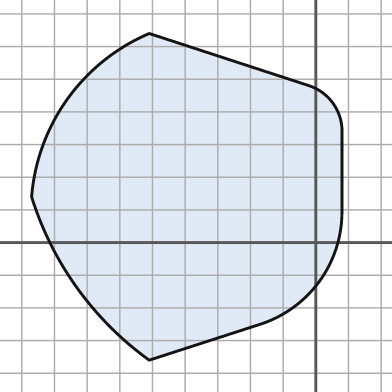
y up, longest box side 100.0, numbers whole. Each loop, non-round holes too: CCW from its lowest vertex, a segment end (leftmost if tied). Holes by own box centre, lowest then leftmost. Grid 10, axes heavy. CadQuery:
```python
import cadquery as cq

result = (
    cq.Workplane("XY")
    .moveTo(-51.0, -36.0)
    .lineTo(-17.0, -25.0)
    .threePointArc((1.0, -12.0), (8.0, 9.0))
    .lineTo(8.0, 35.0)
    .threePointArc((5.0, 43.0), (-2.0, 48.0))
    .lineTo(-51.0, 64.0)
    .threePointArc((-76.0, 44.0), (-87.0, 14.0))
    .threePointArc((-73.0, -14.0), (-51.0, -36.0))
    .close()
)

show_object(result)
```